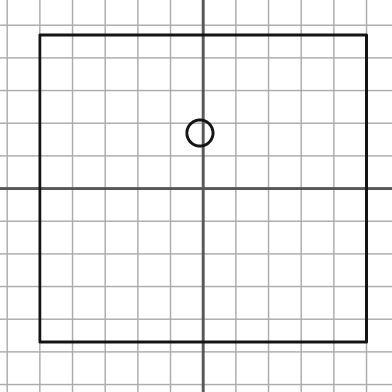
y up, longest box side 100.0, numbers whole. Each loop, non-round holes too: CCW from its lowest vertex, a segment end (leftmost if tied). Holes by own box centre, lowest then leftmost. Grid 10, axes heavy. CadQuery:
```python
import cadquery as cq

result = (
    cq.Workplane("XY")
    .moveTo(-50.0, -47.0)
    .lineTo(50.0, -47.0)
    .lineTo(50.0, 47.0)
    .lineTo(-50.0, 47.0)
    .close()
    .moveTo(-1.0, 17.0)
    .circle(4.0)
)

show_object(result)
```